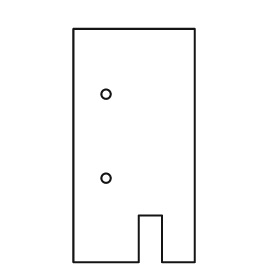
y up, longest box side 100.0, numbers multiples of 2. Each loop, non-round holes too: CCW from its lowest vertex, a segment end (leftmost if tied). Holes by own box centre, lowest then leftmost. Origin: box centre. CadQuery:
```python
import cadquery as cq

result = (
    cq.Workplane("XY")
    .moveTo(-26.0, -50.0)
    .lineTo(2.0, -50.0)
    .lineTo(2.0, -30.0)
    .lineTo(12.0, -30.0)
    .lineTo(12.0, -50.0)
    .lineTo(26.0, -50.0)
    .lineTo(26.0, 50.0)
    .lineTo(-26.0, 50.0)
    .close()
    .moveTo(-12.0, -14.0)
    .circle(2.0)
    .moveTo(-12.0, 22.0)
    .circle(2.0)
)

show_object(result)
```